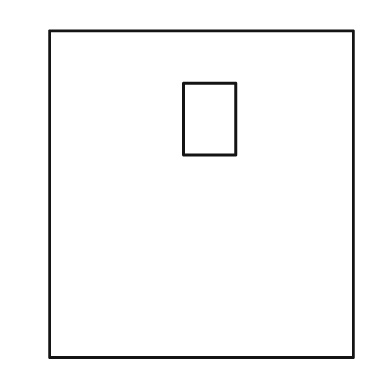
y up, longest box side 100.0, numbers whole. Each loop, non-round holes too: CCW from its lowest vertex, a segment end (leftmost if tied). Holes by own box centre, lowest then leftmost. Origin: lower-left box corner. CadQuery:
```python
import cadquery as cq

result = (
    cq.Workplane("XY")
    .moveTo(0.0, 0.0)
    .lineTo(93.0, 0.0)
    .lineTo(93.0, 100.0)
    .lineTo(0.0, 100.0)
    .close()
    .moveTo(41.0, 62.0)
    .lineTo(57.0, 62.0)
    .lineTo(57.0, 84.0)
    .lineTo(41.0, 84.0)
    .close()
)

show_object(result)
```